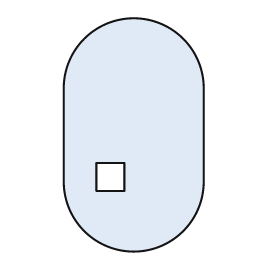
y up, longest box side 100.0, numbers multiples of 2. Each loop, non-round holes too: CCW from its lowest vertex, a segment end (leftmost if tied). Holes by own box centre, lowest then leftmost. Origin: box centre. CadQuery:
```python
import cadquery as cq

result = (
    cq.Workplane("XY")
    .moveTo(-30.0, -20.0)
    .threePointArc((0.0, -50.0), (30.0, -20.0))
    .lineTo(30.0, 20.0)
    .threePointArc((0.0, 50.0), (-30.0, 20.0))
    .close()
    .moveTo(-16.0, -24.0)
    .lineTo(-4.0, -24.0)
    .lineTo(-4.0, -12.0)
    .lineTo(-16.0, -12.0)
    .close()
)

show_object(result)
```